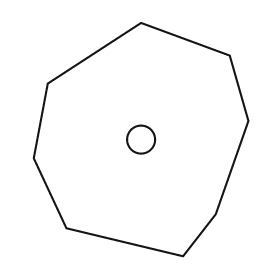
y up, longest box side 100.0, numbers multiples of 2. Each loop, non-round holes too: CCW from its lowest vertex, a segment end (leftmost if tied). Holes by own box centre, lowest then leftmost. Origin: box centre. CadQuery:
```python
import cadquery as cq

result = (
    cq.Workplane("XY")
    .moveTo(18.0, -50.0)
    .lineTo(32.0, -32.0)
    .lineTo(46.0, 8.0)
    .lineTo(38.0, 36.0)
    .lineTo(0.0, 50.0)
    .lineTo(-40.0, 24.0)
    .lineTo(-46.0, -8.0)
    .lineTo(-32.0, -38.0)
    .close()
    .moveTo(0.0, 0.0)
    .circle(6.0)
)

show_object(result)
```